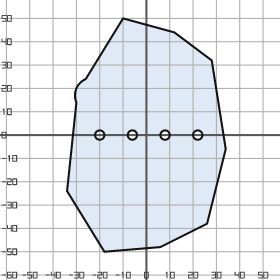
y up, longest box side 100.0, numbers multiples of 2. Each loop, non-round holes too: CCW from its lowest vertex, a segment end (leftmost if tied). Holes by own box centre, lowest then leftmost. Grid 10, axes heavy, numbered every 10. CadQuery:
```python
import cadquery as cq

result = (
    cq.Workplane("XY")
    .moveTo(-18.0, -50.0)
    .lineTo(6.0, -48.0)
    .lineTo(26.0, -38.0)
    .lineTo(34.0, -6.0)
    .lineTo(28.0, 32.0)
    .lineTo(12.0, 44.0)
    .lineTo(-10.0, 50.0)
    .lineTo(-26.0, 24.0)
    .threePointArc((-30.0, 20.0), (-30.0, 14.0))
    .lineTo(-34.0, -24.0)
    .close()
    .moveTo(-20.0, 0.0)
    .circle(2.0)
    .moveTo(-6.0, 0.0)
    .circle(2.0)
    .moveTo(8.0, 0.0)
    .circle(2.0)
    .moveTo(22.0, 0.0)
    .circle(2.0)
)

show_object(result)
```